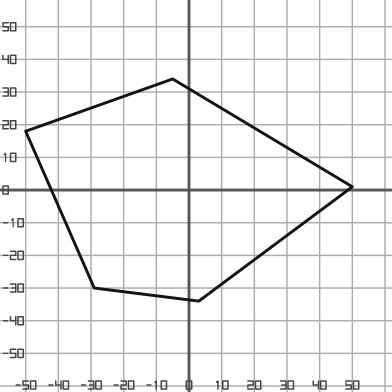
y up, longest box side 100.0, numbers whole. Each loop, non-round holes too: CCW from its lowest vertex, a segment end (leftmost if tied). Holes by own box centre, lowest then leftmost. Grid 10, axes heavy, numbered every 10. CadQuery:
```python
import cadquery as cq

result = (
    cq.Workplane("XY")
    .moveTo(3.0, -34.0)
    .lineTo(50.0, 1.0)
    .lineTo(-5.0, 34.0)
    .lineTo(-50.0, 18.0)
    .lineTo(-29.0, -30.0)
    .close()
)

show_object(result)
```